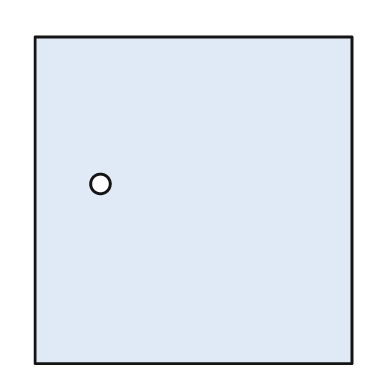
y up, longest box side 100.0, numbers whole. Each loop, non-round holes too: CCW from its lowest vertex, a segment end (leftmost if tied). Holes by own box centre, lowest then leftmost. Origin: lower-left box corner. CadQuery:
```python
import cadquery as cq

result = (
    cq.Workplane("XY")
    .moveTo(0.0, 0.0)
    .lineTo(97.0, 0.0)
    .lineTo(97.0, 100.0)
    .lineTo(0.0, 100.0)
    .close()
    .moveTo(20.0, 55.0)
    .circle(3.0)
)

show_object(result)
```